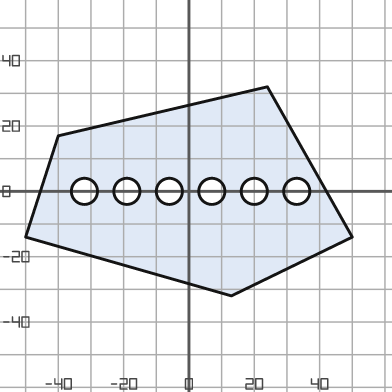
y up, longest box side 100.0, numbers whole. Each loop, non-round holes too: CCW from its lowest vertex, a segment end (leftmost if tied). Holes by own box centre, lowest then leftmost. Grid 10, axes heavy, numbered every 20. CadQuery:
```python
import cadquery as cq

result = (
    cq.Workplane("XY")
    .moveTo(13.0, -32.0)
    .lineTo(50.0, -14.0)
    .lineTo(24.0, 32.0)
    .lineTo(-40.0, 17.0)
    .lineTo(-50.0, -14.0)
    .close()
    .moveTo(-32.0, 0.0)
    .circle(4.0)
    .moveTo(-19.0, 0.0)
    .circle(4.0)
    .moveTo(-6.0, 0.0)
    .circle(4.0)
    .moveTo(7.0, 0.0)
    .circle(4.0)
    .moveTo(20.0, 0.0)
    .circle(4.0)
    .moveTo(33.0, 0.0)
    .circle(4.0)
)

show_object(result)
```